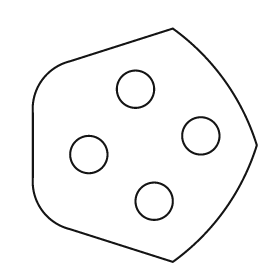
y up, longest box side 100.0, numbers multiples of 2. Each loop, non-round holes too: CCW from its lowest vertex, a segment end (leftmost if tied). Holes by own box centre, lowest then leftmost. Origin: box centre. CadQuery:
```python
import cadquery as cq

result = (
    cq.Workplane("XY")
    .moveTo(12.0, -50.0)
    .threePointArc((34.0, -28.0), (48.0, 0.0))
    .threePointArc((34.0, 28.0), (12.0, 50.0))
    .lineTo(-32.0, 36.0)
    .threePointArc((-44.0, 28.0), (-48.0, 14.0))
    .lineTo(-48.0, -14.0)
    .threePointArc((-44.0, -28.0), (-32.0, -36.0))
    .close()
    .moveTo(4.0, -24.0)
    .circle(8.0)
    .moveTo(-24.0, -4.0)
    .circle(8.0)
    .moveTo(24.0, 4.0)
    .circle(8.0)
    .moveTo(-4.0, 24.0)
    .circle(8.0)
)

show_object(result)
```